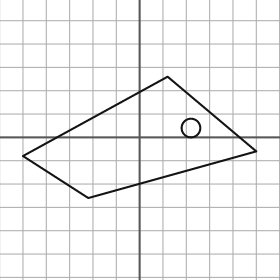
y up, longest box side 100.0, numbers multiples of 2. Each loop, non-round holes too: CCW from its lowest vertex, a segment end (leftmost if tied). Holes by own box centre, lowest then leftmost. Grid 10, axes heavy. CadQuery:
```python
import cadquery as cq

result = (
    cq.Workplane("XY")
    .moveTo(-22.0, -26.0)
    .lineTo(50.0, -6.0)
    .lineTo(12.0, 26.0)
    .lineTo(-50.0, -8.0)
    .close()
    .moveTo(22.0, 4.0)
    .circle(4.0)
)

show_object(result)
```